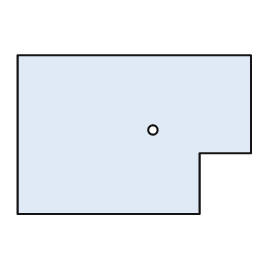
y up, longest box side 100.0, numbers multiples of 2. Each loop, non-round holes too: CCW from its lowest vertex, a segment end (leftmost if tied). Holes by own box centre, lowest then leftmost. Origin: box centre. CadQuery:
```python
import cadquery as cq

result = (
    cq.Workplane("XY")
    .moveTo(-50.0, -34.0)
    .lineTo(28.0, -34.0)
    .lineTo(28.0, -8.0)
    .lineTo(50.0, -8.0)
    .lineTo(50.0, 34.0)
    .lineTo(-50.0, 34.0)
    .close()
    .moveTo(8.0, 2.0)
    .circle(2.0)
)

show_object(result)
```